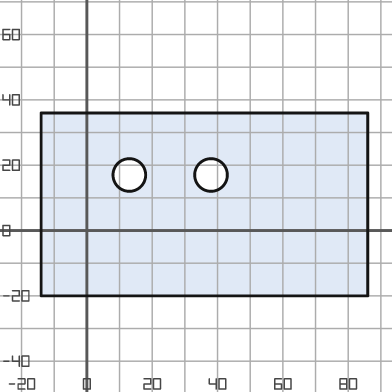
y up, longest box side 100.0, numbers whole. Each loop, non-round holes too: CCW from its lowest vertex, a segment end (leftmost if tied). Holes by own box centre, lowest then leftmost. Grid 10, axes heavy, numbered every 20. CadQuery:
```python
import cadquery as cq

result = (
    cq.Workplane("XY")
    .moveTo(-14.0, -20.0)
    .lineTo(86.0, -20.0)
    .lineTo(86.0, 36.0)
    .lineTo(-14.0, 36.0)
    .close()
    .moveTo(13.0, 17.0)
    .circle(5.0)
    .moveTo(38.0, 17.0)
    .circle(5.0)
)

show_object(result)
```